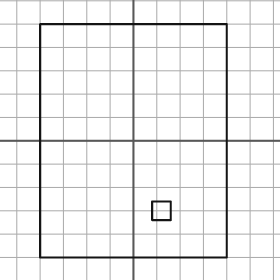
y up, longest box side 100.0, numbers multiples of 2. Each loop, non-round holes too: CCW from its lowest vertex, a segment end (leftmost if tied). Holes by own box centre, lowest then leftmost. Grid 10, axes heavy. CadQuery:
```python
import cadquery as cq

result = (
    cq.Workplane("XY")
    .moveTo(-40.0, -50.0)
    .lineTo(40.0, -50.0)
    .lineTo(40.0, 50.0)
    .lineTo(-40.0, 50.0)
    .close()
    .moveTo(8.0, -34.0)
    .lineTo(16.0, -34.0)
    .lineTo(16.0, -26.0)
    .lineTo(8.0, -26.0)
    .close()
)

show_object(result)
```